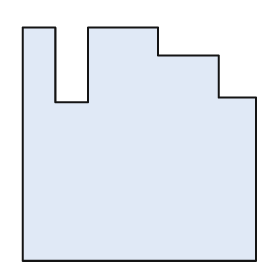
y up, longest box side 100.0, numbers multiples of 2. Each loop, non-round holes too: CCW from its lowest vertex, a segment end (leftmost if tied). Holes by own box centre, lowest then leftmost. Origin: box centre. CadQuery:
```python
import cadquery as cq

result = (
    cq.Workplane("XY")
    .moveTo(-50.0, -50.0)
    .lineTo(50.0, -50.0)
    .lineTo(50.0, 20.0)
    .lineTo(34.0, 20.0)
    .lineTo(34.0, 38.0)
    .lineTo(8.0, 38.0)
    .lineTo(8.0, 50.0)
    .lineTo(-22.0, 50.0)
    .lineTo(-22.0, 18.0)
    .lineTo(-36.0, 18.0)
    .lineTo(-36.0, 50.0)
    .lineTo(-50.0, 50.0)
    .close()
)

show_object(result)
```